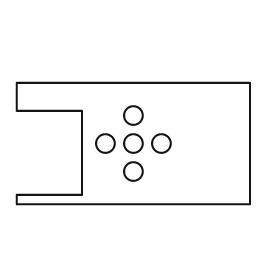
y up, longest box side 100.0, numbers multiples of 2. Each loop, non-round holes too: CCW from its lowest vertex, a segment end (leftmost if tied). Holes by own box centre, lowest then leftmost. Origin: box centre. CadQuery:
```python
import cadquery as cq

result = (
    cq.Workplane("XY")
    .moveTo(-50.0, -26.0)
    .lineTo(50.0, -26.0)
    .lineTo(50.0, 26.0)
    .lineTo(-50.0, 26.0)
    .lineTo(-50.0, 14.0)
    .lineTo(-22.0, 14.0)
    .lineTo(-22.0, -22.0)
    .lineTo(-50.0, -22.0)
    .close()
    .moveTo(0.0, -12.0)
    .circle(4.0)
    .moveTo(-12.0, 0.0)
    .circle(4.0)
    .moveTo(0.0, 0.0)
    .circle(4.0)
    .moveTo(12.0, 0.0)
    .circle(4.0)
    .moveTo(0.0, 12.0)
    .circle(4.0)
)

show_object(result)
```